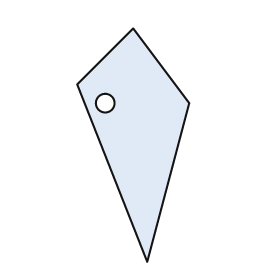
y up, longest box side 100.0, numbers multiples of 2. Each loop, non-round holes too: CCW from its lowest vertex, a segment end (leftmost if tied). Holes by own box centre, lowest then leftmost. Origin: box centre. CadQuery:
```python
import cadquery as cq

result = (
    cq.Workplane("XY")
    .moveTo(6.0, -50.0)
    .lineTo(24.0, 18.0)
    .lineTo(0.0, 50.0)
    .lineTo(-24.0, 26.0)
    .close()
    .moveTo(-12.0, 18.0)
    .circle(4.0)
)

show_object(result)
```